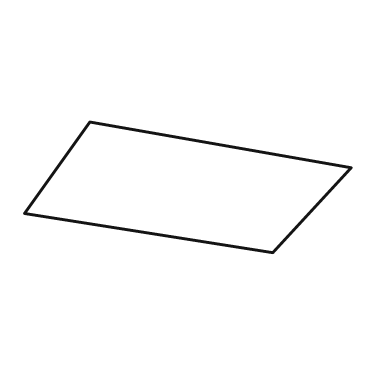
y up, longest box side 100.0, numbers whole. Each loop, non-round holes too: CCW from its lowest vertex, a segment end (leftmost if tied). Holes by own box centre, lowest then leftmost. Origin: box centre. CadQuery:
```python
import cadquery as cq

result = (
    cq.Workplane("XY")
    .moveTo(26.0, -20.0)
    .lineTo(50.0, 6.0)
    .lineTo(-30.0, 20.0)
    .lineTo(-50.0, -8.0)
    .close()
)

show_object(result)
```